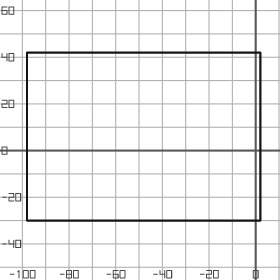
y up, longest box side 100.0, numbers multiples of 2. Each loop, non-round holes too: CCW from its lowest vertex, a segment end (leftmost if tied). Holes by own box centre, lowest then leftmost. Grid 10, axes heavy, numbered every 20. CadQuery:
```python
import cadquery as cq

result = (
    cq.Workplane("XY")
    .moveTo(-98.0, -30.0)
    .lineTo(2.0, -30.0)
    .lineTo(2.0, 42.0)
    .lineTo(-98.0, 42.0)
    .close()
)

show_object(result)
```